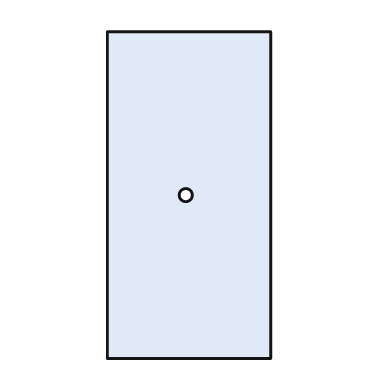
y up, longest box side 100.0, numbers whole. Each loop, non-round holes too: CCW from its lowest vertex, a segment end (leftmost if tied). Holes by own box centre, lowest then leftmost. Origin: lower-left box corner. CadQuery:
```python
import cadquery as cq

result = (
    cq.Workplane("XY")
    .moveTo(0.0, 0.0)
    .lineTo(50.0, 0.0)
    .lineTo(50.0, 100.0)
    .lineTo(0.0, 100.0)
    .close()
    .moveTo(24.0, 50.0)
    .circle(2.0)
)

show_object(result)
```